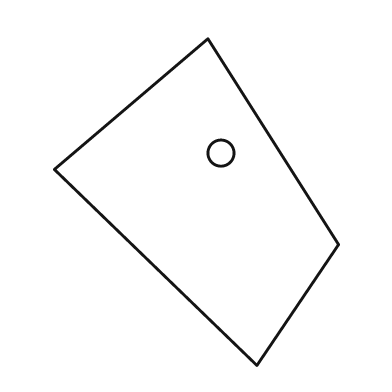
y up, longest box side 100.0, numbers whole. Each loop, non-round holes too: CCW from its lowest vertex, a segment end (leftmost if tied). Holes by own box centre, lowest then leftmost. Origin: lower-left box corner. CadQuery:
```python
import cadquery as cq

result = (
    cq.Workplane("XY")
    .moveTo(62.0, 0.0)
    .lineTo(87.0, 37.0)
    .lineTo(47.0, 100.0)
    .lineTo(0.0, 60.0)
    .close()
    .moveTo(51.0, 65.0)
    .circle(4.0)
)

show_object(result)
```